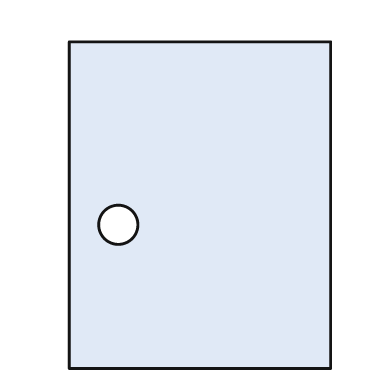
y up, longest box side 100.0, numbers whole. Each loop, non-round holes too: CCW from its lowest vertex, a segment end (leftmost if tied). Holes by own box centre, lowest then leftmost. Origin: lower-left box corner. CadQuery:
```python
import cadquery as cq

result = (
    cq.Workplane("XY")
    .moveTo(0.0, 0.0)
    .lineTo(80.0, 0.0)
    .lineTo(80.0, 100.0)
    .lineTo(0.0, 100.0)
    .close()
    .moveTo(15.0, 44.0)
    .circle(6.0)
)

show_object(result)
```